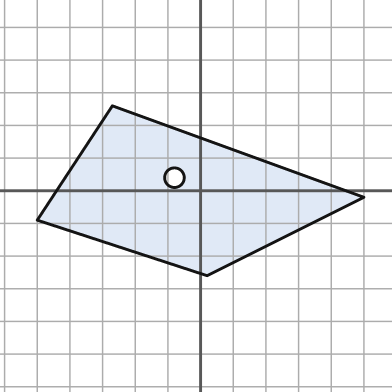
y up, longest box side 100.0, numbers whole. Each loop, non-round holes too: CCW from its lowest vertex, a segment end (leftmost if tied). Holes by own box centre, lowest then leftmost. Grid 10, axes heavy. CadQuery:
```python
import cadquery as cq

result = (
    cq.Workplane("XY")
    .moveTo(2.0, -26.0)
    .lineTo(50.0, -2.0)
    .lineTo(-27.0, 26.0)
    .lineTo(-50.0, -9.0)
    .close()
    .moveTo(-8.0, 4.0)
    .circle(3.0)
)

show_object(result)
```